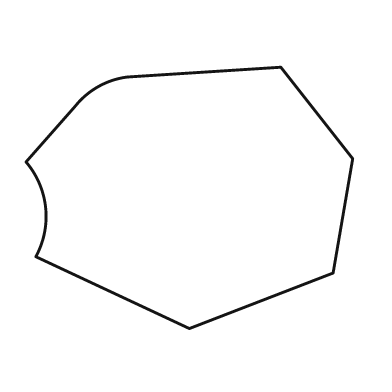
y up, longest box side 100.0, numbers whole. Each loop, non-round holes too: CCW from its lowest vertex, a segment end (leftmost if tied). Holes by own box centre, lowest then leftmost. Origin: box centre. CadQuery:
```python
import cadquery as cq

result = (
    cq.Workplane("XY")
    .moveTo(0.0, -40.0)
    .lineTo(44.0, -23.0)
    .lineTo(50.0, 12.0)
    .lineTo(28.0, 40.0)
    .lineTo(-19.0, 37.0)
    .threePointArc((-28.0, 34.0), (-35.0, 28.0))
    .lineTo(-50.0, 11.0)
    .threePointArc((-44.0, -3.0), (-47.0, -18.0))
    .close()
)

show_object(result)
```